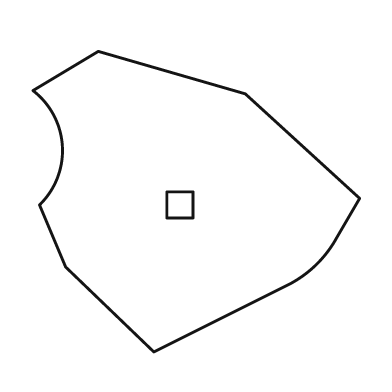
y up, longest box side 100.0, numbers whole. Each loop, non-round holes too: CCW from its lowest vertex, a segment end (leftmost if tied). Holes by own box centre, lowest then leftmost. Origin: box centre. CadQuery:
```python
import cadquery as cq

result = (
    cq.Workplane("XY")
    .moveTo(-13.0, -46.0)
    .lineTo(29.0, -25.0)
    .threePointArc((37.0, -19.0), (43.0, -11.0))
    .lineTo(50.0, 1.0)
    .lineTo(15.0, 33.0)
    .lineTo(-30.0, 46.0)
    .lineTo(-50.0, 34.0)
    .threePointArc((-41.0, 17.0), (-48.0, -1.0))
    .lineTo(-40.0, -20.0)
    .close()
    .moveTo(-9.0, -5.0)
    .lineTo(-1.0, -5.0)
    .lineTo(-1.0, 3.0)
    .lineTo(-9.0, 3.0)
    .close()
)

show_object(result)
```